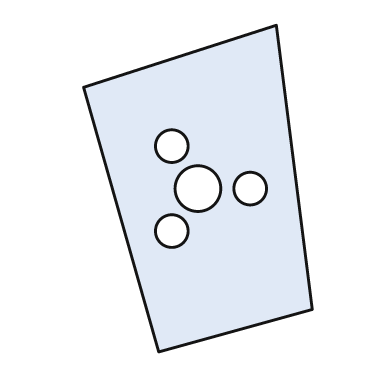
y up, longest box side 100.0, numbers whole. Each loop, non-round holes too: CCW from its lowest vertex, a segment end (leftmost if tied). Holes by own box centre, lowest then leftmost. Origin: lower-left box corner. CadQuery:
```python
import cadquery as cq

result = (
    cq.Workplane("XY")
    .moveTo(23.0, 0.0)
    .lineTo(70.0, 13.0)
    .lineTo(59.0, 100.0)
    .lineTo(0.0, 81.0)
    .close()
    .moveTo(27.0, 37.0)
    .circle(5.0)
    .moveTo(35.0, 50.0)
    .circle(7.0)
    .moveTo(51.0, 50.0)
    .circle(5.0)
    .moveTo(27.0, 63.0)
    .circle(5.0)
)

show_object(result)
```